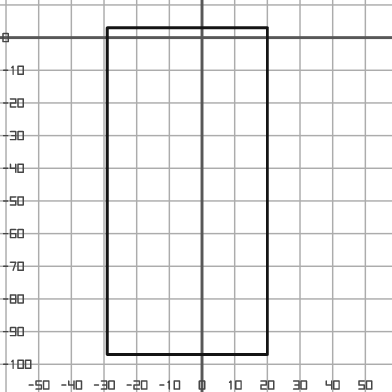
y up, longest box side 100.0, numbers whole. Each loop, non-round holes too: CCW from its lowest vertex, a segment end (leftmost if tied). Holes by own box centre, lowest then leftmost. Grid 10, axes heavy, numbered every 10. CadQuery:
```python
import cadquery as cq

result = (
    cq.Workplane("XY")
    .moveTo(-29.0, -97.0)
    .lineTo(20.0, -97.0)
    .lineTo(20.0, 3.0)
    .lineTo(-29.0, 3.0)
    .close()
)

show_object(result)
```